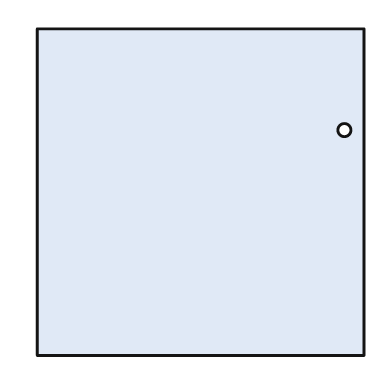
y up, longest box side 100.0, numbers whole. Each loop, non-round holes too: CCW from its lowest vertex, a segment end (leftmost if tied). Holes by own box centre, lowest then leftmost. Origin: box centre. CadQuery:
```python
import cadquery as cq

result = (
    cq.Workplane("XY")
    .moveTo(-50.0, -50.0)
    .lineTo(50.0, -50.0)
    .lineTo(50.0, 50.0)
    .lineTo(-50.0, 50.0)
    .close()
    .moveTo(44.0, 19.0)
    .circle(2.0)
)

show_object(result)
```